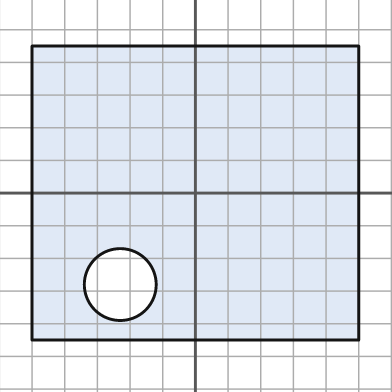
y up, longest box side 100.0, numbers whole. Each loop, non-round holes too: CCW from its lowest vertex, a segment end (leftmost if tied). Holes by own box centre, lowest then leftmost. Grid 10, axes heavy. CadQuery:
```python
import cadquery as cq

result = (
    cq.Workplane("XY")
    .moveTo(-50.0, -45.0)
    .lineTo(50.0, -45.0)
    .lineTo(50.0, 45.0)
    .lineTo(-50.0, 45.0)
    .close()
    .moveTo(-23.0, -28.0)
    .circle(11.0)
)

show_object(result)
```